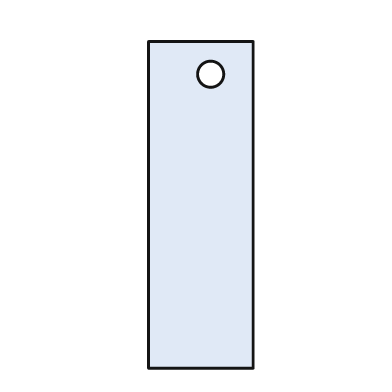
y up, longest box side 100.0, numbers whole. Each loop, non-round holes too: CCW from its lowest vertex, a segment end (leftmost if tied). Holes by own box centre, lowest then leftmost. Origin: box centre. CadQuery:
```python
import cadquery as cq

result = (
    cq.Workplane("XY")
    .moveTo(-16.0, -50.0)
    .lineTo(16.0, -50.0)
    .lineTo(16.0, 50.0)
    .lineTo(-16.0, 50.0)
    .close()
    .moveTo(3.0, 40.0)
    .circle(4.0)
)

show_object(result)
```